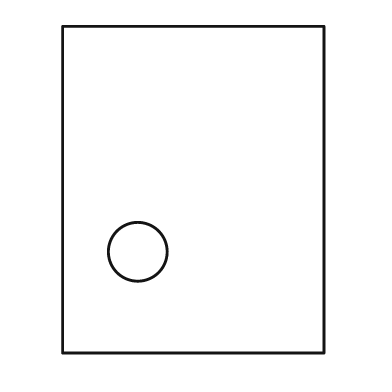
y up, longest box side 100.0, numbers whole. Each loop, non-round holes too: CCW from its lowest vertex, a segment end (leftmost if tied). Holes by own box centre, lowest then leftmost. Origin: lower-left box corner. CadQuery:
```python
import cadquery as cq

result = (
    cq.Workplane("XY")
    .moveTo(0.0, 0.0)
    .lineTo(80.0, 0.0)
    .lineTo(80.0, 100.0)
    .lineTo(0.0, 100.0)
    .close()
    .moveTo(23.0, 31.0)
    .circle(9.0)
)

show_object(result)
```